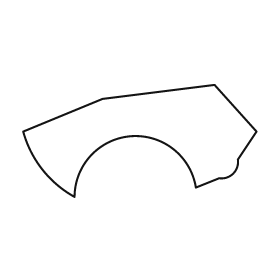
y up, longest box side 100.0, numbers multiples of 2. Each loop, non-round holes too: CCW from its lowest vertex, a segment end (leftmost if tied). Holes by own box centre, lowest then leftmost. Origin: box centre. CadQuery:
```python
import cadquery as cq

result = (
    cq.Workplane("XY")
    .moveTo(-28.0, -24.0)
    .threePointArc((-4.0, 2.0), (24.0, -20.0))
    .lineTo(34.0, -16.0)
    .threePointArc((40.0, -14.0), (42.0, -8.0))
    .lineTo(50.0, 4.0)
    .lineTo(32.0, 24.0)
    .lineTo(-16.0, 18.0)
    .lineTo(-50.0, 4.0)
    .threePointArc((-42.0, -12.0), (-28.0, -24.0))
    .close()
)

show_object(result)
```